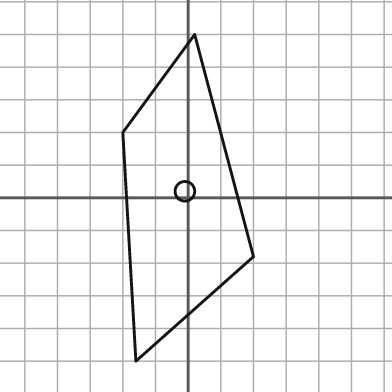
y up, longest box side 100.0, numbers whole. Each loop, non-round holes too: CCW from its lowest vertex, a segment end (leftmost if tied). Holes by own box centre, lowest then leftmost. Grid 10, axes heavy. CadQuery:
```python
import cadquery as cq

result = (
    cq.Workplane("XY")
    .moveTo(-16.0, -50.0)
    .lineTo(20.0, -18.0)
    .lineTo(2.0, 50.0)
    .lineTo(-20.0, 20.0)
    .close()
    .moveTo(-1.0, 2.0)
    .circle(3.0)
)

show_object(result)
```